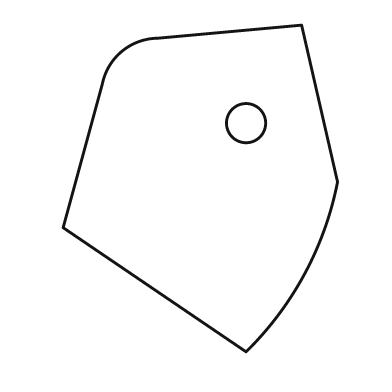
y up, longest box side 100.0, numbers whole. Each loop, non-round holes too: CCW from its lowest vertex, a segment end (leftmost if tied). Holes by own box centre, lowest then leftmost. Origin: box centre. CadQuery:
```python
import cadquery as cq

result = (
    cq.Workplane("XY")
    .moveTo(14.0, -50.0)
    .threePointArc((32.0, -26.0), (42.0, 2.0))
    .lineTo(31.0, 50.0)
    .lineTo(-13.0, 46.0)
    .threePointArc((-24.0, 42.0), (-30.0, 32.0))
    .lineTo(-42.0, -12.0)
    .close()
    .moveTo(14.0, 20.0)
    .circle(6.0)
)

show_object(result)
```